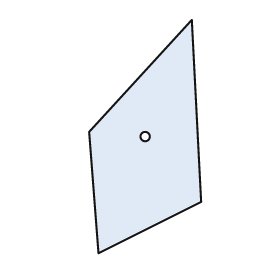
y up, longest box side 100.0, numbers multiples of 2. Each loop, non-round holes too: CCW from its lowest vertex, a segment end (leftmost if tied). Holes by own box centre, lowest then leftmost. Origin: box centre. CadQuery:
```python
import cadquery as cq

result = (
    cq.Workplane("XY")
    .moveTo(-20.0, -50.0)
    .lineTo(24.0, -28.0)
    .lineTo(20.0, 50.0)
    .lineTo(-24.0, 2.0)
    .close()
    .moveTo(0.0, 0.0)
    .circle(2.0)
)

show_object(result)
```